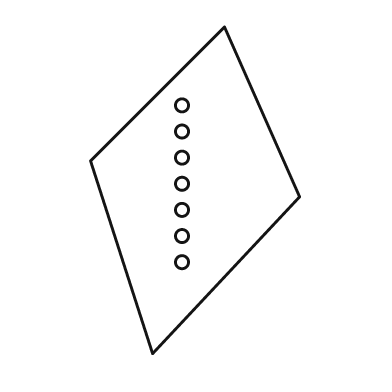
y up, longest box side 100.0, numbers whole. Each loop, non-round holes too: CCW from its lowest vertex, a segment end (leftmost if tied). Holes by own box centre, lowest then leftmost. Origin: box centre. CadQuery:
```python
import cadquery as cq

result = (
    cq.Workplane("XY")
    .moveTo(-13.0, -50.0)
    .lineTo(32.0, -2.0)
    .lineTo(9.0, 50.0)
    .lineTo(-32.0, 9.0)
    .close()
    .moveTo(-4.0, -22.0)
    .circle(2.0)
    .moveTo(-4.0, -14.0)
    .circle(2.0)
    .moveTo(-4.0, -6.0)
    .circle(2.0)
    .moveTo(-4.0, 2.0)
    .circle(2.0)
    .moveTo(-4.0, 10.0)
    .circle(2.0)
    .moveTo(-4.0, 18.0)
    .circle(2.0)
    .moveTo(-4.0, 26.0)
    .circle(2.0)
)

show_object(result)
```